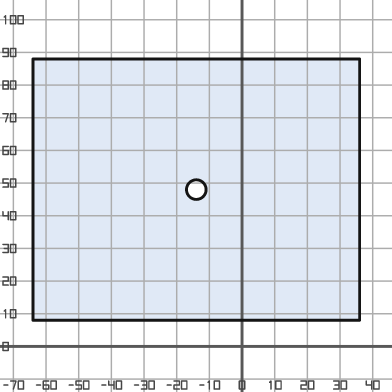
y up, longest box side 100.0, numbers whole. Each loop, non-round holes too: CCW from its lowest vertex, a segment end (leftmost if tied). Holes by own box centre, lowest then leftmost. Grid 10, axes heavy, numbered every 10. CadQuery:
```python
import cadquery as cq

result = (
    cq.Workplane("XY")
    .moveTo(-64.0, 8.0)
    .lineTo(36.0, 8.0)
    .lineTo(36.0, 88.0)
    .lineTo(-64.0, 88.0)
    .close()
    .moveTo(-14.0, 48.0)
    .circle(3.0)
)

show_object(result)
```